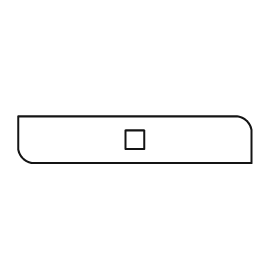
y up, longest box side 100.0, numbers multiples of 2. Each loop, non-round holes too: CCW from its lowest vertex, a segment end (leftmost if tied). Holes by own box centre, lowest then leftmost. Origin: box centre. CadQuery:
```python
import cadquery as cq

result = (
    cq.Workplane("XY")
    .moveTo(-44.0, -10.0)
    .lineTo(50.0, -10.0)
    .lineTo(50.0, 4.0)
    .threePointArc((48.0, 8.0), (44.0, 10.0))
    .lineTo(-50.0, 10.0)
    .lineTo(-50.0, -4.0)
    .threePointArc((-48.0, -8.0), (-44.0, -10.0))
    .close()
    .moveTo(-4.0, -4.0)
    .lineTo(4.0, -4.0)
    .lineTo(4.0, 4.0)
    .lineTo(-4.0, 4.0)
    .close()
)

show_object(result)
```